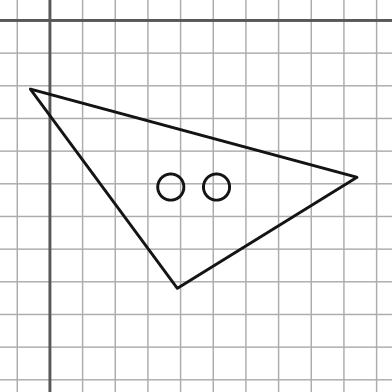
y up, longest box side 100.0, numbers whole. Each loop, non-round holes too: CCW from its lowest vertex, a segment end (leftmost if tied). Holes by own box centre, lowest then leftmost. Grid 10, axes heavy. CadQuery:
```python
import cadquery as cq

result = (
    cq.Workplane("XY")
    .moveTo(39.0, -82.0)
    .lineTo(94.0, -48.0)
    .lineTo(-6.0, -21.0)
    .close()
    .moveTo(37.0, -51.0)
    .circle(4.0)
    .moveTo(51.0, -51.0)
    .circle(4.0)
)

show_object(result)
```